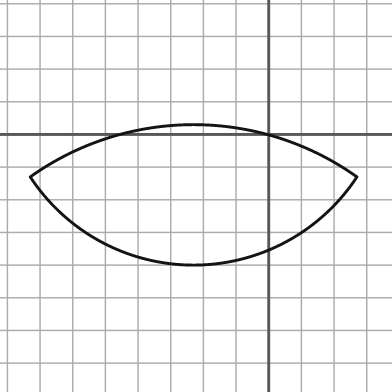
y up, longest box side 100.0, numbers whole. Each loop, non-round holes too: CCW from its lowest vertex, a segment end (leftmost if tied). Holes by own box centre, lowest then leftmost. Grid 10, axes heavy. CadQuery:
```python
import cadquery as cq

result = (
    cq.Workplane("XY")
    .moveTo(-73.0, -13.0)
    .threePointArc((-23.0, -40.0), (27.0, -13.0))
    .threePointArc((-23.0, 3.0), (-73.0, -13.0))
    .close()
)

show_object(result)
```